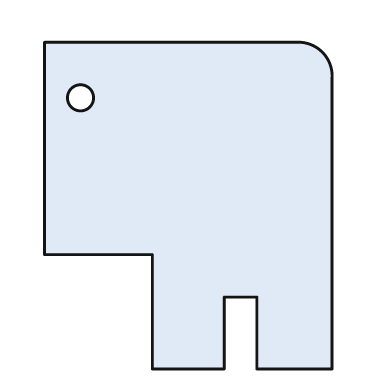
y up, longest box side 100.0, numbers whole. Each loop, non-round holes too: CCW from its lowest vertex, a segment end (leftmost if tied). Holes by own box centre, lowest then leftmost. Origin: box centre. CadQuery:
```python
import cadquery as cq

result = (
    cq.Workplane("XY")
    .moveTo(-11.0, -50.0)
    .lineTo(11.0, -50.0)
    .lineTo(11.0, -28.0)
    .lineTo(21.0, -28.0)
    .lineTo(21.0, -50.0)
    .lineTo(44.0, -50.0)
    .lineTo(44.0, 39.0)
    .threePointArc((41.0, 47.0), (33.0, 50.0))
    .lineTo(-44.0, 50.0)
    .lineTo(-44.0, -15.0)
    .lineTo(-11.0, -15.0)
    .close()
    .moveTo(-33.0, 33.0)
    .circle(4.0)
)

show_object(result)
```